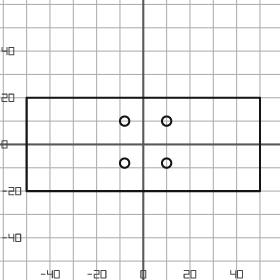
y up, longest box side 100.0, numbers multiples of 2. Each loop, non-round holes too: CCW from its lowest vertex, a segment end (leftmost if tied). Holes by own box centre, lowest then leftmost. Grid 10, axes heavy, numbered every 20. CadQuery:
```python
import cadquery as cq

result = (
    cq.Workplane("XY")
    .moveTo(-50.0, -20.0)
    .lineTo(50.0, -20.0)
    .lineTo(50.0, 20.0)
    .lineTo(-50.0, 20.0)
    .close()
    .moveTo(-8.0, -8.0)
    .circle(2.0)
    .moveTo(10.0, -8.0)
    .circle(2.0)
    .moveTo(-8.0, 10.0)
    .circle(2.0)
    .moveTo(10.0, 10.0)
    .circle(2.0)
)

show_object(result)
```